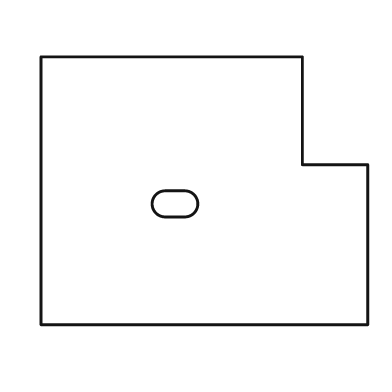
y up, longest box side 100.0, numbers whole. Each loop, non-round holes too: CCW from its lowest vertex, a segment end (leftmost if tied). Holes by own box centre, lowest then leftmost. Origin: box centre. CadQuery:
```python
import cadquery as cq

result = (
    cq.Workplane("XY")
    .moveTo(-50.0, -41.0)
    .lineTo(50.0, -41.0)
    .lineTo(50.0, 8.0)
    .lineTo(30.0, 8.0)
    .lineTo(30.0, 41.0)
    .lineTo(-50.0, 41.0)
    .close()
    .moveTo(-12.0, -8.0)
    .lineTo(-6.0, -8.0)
    .threePointArc((-2.0, -4.0), (-6.0, 0.0))
    .lineTo(-12.0, 0.0)
    .threePointArc((-16.0, -4.0), (-12.0, -8.0))
    .close()
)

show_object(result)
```